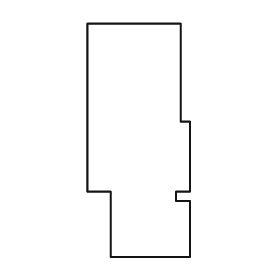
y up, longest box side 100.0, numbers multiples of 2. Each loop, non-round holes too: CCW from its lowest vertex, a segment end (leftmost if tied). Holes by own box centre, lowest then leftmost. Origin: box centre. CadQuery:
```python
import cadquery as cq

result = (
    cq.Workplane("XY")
    .moveTo(-12.0, -50.0)
    .lineTo(22.0, -50.0)
    .lineTo(22.0, -26.0)
    .lineTo(16.0, -26.0)
    .lineTo(16.0, -22.0)
    .lineTo(22.0, -22.0)
    .lineTo(22.0, 8.0)
    .lineTo(18.0, 8.0)
    .lineTo(18.0, 50.0)
    .lineTo(-22.0, 50.0)
    .lineTo(-22.0, -22.0)
    .lineTo(-12.0, -22.0)
    .close()
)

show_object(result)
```